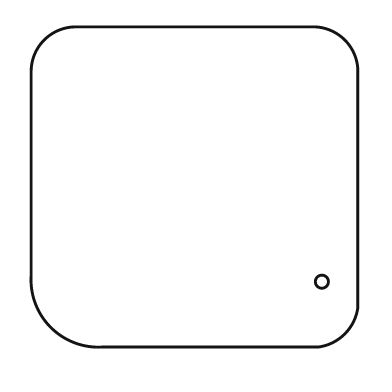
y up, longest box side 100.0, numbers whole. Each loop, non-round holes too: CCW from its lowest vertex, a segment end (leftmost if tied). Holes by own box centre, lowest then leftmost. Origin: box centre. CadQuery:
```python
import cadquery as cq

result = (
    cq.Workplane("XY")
    .moveTo(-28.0, -49.0)
    .lineTo(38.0, -49.0)
    .threePointArc((46.0, -45.0), (50.0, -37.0))
    .lineTo(50.0, 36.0)
    .threePointArc((46.0, 45.0), (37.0, 49.0))
    .lineTo(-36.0, 49.0)
    .threePointArc((-46.0, 45.0), (-50.0, 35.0))
    .lineTo(-50.0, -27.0)
    .threePointArc((-44.0, -43.0), (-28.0, -49.0))
    .close()
    .moveTo(39.0, -29.0)
    .circle(2.0)
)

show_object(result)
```